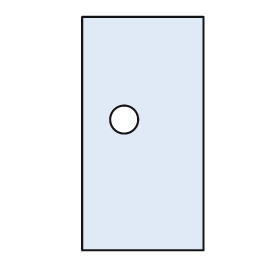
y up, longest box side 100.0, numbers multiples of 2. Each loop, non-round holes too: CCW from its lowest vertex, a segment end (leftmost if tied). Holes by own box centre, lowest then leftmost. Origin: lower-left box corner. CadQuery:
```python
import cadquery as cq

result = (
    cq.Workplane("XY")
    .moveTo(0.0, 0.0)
    .lineTo(52.0, 0.0)
    .lineTo(52.0, 100.0)
    .lineTo(0.0, 100.0)
    .close()
    .moveTo(18.0, 56.0)
    .circle(6.0)
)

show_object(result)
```